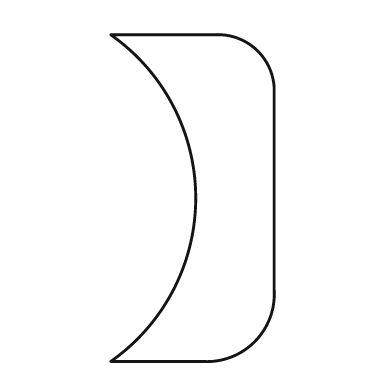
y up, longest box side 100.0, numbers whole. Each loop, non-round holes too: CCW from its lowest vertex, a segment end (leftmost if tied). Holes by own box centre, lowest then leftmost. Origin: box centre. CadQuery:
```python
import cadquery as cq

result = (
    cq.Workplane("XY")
    .moveTo(-25.0, -50.0)
    .lineTo(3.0, -50.0)
    .threePointArc((19.0, -44.0), (25.0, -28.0))
    .lineTo(25.0, 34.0)
    .threePointArc((20.0, 45.0), (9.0, 50.0))
    .lineTo(-25.0, 50.0)
    .threePointArc((1.0, 0.0), (-25.0, -50.0))
    .close()
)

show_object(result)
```